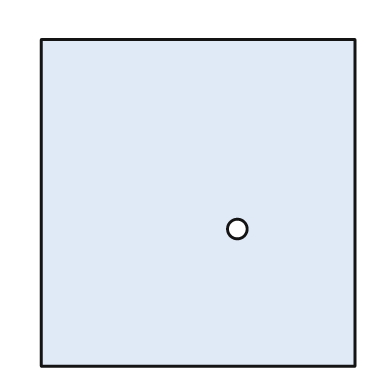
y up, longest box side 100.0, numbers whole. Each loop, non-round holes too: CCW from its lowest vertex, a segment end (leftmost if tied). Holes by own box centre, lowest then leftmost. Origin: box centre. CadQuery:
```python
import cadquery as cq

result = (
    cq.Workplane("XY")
    .moveTo(-48.0, -50.0)
    .lineTo(48.0, -50.0)
    .lineTo(48.0, 50.0)
    .lineTo(-48.0, 50.0)
    .close()
    .moveTo(12.0, -8.0)
    .circle(3.0)
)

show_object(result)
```